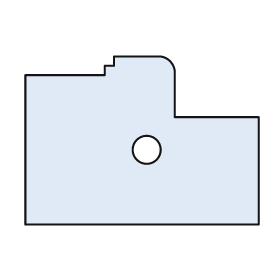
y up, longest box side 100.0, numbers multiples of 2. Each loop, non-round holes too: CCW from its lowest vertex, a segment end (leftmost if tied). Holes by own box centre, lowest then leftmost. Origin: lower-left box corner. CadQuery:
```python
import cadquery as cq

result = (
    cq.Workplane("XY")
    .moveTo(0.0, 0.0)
    .lineTo(100.0, 0.0)
    .lineTo(100.0, 46.0)
    .lineTo(64.0, 46.0)
    .lineTo(64.0, 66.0)
    .threePointArc((62.0, 70.0), (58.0, 72.0))
    .lineTo(38.0, 72.0)
    .lineTo(38.0, 68.0)
    .lineTo(34.0, 68.0)
    .lineTo(34.0, 64.0)
    .lineTo(0.0, 64.0)
    .close()
    .moveTo(52.0, 32.0)
    .circle(6.0)
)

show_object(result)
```